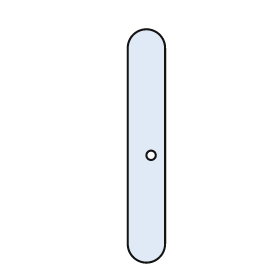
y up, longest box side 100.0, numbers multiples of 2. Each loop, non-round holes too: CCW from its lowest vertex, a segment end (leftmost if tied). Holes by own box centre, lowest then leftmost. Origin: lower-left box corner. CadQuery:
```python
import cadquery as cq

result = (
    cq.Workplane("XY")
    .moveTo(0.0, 8.0)
    .threePointArc((8.0, 0.0), (16.0, 8.0))
    .lineTo(16.0, 92.0)
    .threePointArc((8.0, 100.0), (0.0, 92.0))
    .close()
    .moveTo(10.0, 46.0)
    .circle(2.0)
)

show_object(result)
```